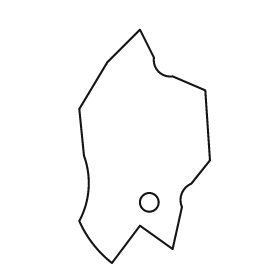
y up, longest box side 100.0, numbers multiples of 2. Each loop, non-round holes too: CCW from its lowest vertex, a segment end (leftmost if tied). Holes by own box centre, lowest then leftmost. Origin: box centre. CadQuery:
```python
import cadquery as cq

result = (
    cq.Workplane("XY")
    .moveTo(-14.0, -50.0)
    .lineTo(-2.0, -34.0)
    .lineTo(12.0, -44.0)
    .lineTo(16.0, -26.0)
    .threePointArc((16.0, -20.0), (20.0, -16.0))
    .lineTo(28.0, -6.0)
    .lineTo(26.0, 24.0)
    .lineTo(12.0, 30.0)
    .threePointArc((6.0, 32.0), (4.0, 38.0))
    .lineTo(-2.0, 50.0)
    .lineTo(-16.0, 36.0)
    .lineTo(-28.0, 16.0)
    .lineTo(-26.0, -4.0)
    .threePointArc((-24.0, -18.0), (-28.0, -32.0))
    .threePointArc((-22.0, -42.0), (-14.0, -50.0))
    .close()
    .moveTo(2.0, -24.0)
    .circle(4.0)
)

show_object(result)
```